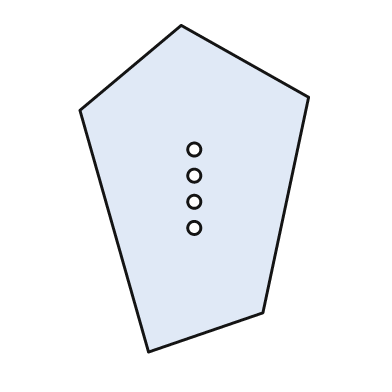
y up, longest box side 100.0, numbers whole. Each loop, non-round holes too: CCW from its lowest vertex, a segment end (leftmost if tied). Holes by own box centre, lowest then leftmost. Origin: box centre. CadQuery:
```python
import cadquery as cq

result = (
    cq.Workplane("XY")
    .moveTo(-14.0, -50.0)
    .lineTo(21.0, -38.0)
    .lineTo(35.0, 28.0)
    .lineTo(-4.0, 50.0)
    .lineTo(-35.0, 24.0)
    .close()
    .moveTo(0.0, -12.0)
    .circle(2.0)
    .moveTo(0.0, -4.0)
    .circle(2.0)
    .moveTo(0.0, 4.0)
    .circle(2.0)
    .moveTo(0.0, 12.0)
    .circle(2.0)
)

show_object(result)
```